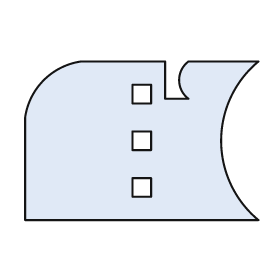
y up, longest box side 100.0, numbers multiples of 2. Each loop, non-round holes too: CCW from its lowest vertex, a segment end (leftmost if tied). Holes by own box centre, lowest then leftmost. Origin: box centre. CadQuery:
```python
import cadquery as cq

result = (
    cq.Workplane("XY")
    .moveTo(-50.0, -34.0)
    .lineTo(50.0, -34.0)
    .threePointArc((34.0, 0.0), (50.0, 34.0))
    .lineTo(20.0, 34.0)
    .threePointArc((16.0, 26.0), (20.0, 18.0))
    .lineTo(10.0, 18.0)
    .lineTo(10.0, 34.0)
    .lineTo(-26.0, 34.0)
    .threePointArc((-42.0, 26.0), (-50.0, 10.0))
    .close()
    .moveTo(-4.0, -24.0)
    .lineTo(4.0, -24.0)
    .lineTo(4.0, -16.0)
    .lineTo(-4.0, -16.0)
    .close()
    .moveTo(-4.0, -4.0)
    .lineTo(4.0, -4.0)
    .lineTo(4.0, 4.0)
    .lineTo(-4.0, 4.0)
    .close()
    .moveTo(-4.0, 16.0)
    .lineTo(4.0, 16.0)
    .lineTo(4.0, 24.0)
    .lineTo(-4.0, 24.0)
    .close()
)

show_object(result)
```